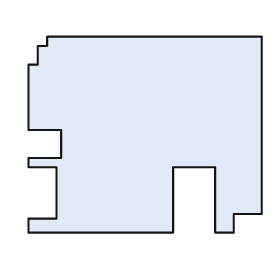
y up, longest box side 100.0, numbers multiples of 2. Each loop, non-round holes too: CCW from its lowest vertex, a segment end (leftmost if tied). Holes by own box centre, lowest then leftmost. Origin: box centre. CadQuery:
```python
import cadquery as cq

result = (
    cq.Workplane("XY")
    .moveTo(-50.0, -42.0)
    .lineTo(12.0, -42.0)
    .lineTo(12.0, -14.0)
    .lineTo(30.0, -14.0)
    .lineTo(30.0, -42.0)
    .lineTo(38.0, -42.0)
    .lineTo(38.0, -34.0)
    .lineTo(50.0, -34.0)
    .lineTo(50.0, 42.0)
    .lineTo(-42.0, 42.0)
    .lineTo(-42.0, 38.0)
    .lineTo(-46.0, 38.0)
    .lineTo(-46.0, 30.0)
    .lineTo(-50.0, 30.0)
    .lineTo(-50.0, 2.0)
    .lineTo(-36.0, 2.0)
    .lineTo(-36.0, -10.0)
    .lineTo(-50.0, -10.0)
    .lineTo(-50.0, -14.0)
    .lineTo(-38.0, -14.0)
    .lineTo(-38.0, -36.0)
    .lineTo(-50.0, -36.0)
    .close()
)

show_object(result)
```